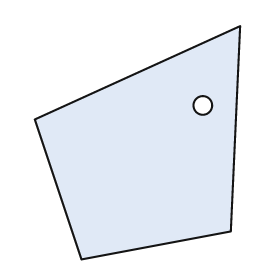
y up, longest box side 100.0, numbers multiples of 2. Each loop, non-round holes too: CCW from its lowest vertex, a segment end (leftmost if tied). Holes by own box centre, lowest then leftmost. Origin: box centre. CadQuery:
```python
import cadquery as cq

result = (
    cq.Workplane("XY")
    .moveTo(-24.0, -50.0)
    .lineTo(40.0, -38.0)
    .lineTo(44.0, 50.0)
    .lineTo(-44.0, 10.0)
    .close()
    .moveTo(28.0, 16.0)
    .circle(4.0)
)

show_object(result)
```